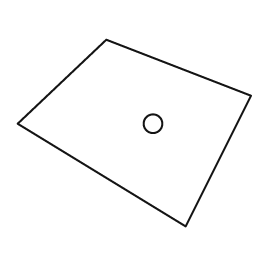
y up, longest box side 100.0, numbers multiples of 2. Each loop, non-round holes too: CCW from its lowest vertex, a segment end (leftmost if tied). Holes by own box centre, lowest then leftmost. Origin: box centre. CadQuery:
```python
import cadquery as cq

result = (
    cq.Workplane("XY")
    .moveTo(22.0, -40.0)
    .lineTo(50.0, 16.0)
    .lineTo(-12.0, 40.0)
    .lineTo(-50.0, 4.0)
    .close()
    .moveTo(8.0, 4.0)
    .circle(4.0)
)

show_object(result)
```